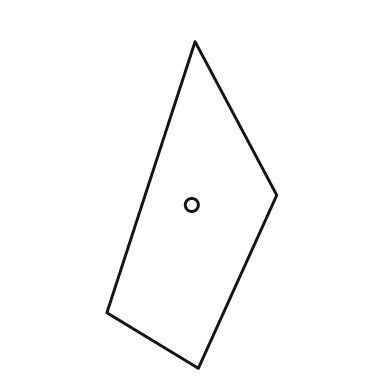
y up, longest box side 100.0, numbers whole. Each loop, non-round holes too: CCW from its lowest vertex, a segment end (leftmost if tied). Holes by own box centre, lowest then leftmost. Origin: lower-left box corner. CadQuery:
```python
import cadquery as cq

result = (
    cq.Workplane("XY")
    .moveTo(28.0, 0.0)
    .lineTo(52.0, 53.0)
    .lineTo(27.0, 100.0)
    .lineTo(0.0, 17.0)
    .close()
    .moveTo(26.0, 50.0)
    .circle(2.0)
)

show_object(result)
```